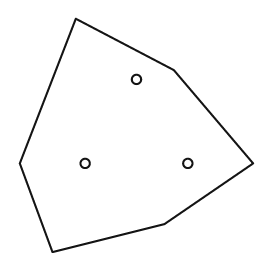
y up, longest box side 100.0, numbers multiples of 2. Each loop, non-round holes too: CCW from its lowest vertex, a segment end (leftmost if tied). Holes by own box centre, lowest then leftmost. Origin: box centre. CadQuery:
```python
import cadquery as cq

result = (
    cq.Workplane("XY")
    .moveTo(-36.0, -50.0)
    .lineTo(12.0, -38.0)
    .lineTo(50.0, -12.0)
    .lineTo(16.0, 28.0)
    .lineTo(-26.0, 50.0)
    .lineTo(-50.0, -12.0)
    .close()
    .moveTo(-22.0, -12.0)
    .circle(2.0)
    .moveTo(22.0, -12.0)
    .circle(2.0)
    .moveTo(0.0, 24.0)
    .circle(2.0)
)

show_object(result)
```